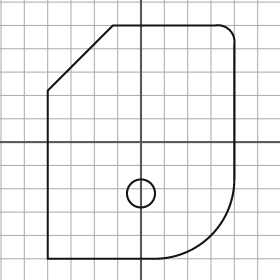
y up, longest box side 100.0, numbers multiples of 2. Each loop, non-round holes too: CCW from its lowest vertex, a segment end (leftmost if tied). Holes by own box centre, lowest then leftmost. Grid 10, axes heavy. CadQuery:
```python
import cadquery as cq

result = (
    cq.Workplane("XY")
    .moveTo(-40.0, -50.0)
    .lineTo(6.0, -50.0)
    .threePointArc((30.0, -40.0), (40.0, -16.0))
    .lineTo(40.0, 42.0)
    .threePointArc((38.0, 48.0), (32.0, 50.0))
    .lineTo(-12.0, 50.0)
    .lineTo(-40.0, 22.0)
    .close()
    .moveTo(0.0, -22.0)
    .circle(6.0)
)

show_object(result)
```